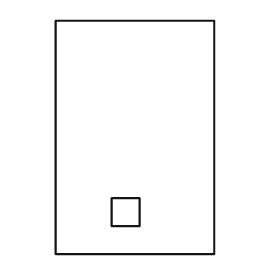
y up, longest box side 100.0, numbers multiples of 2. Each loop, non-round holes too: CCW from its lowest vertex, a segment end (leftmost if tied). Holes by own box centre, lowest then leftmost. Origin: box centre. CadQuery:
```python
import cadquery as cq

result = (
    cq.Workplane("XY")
    .moveTo(-34.0, -50.0)
    .lineTo(34.0, -50.0)
    .lineTo(34.0, 50.0)
    .lineTo(-34.0, 50.0)
    .close()
    .moveTo(-10.0, -38.0)
    .lineTo(2.0, -38.0)
    .lineTo(2.0, -26.0)
    .lineTo(-10.0, -26.0)
    .close()
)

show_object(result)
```